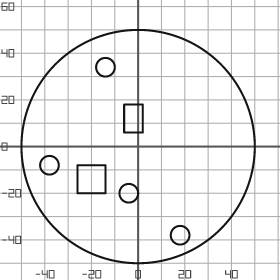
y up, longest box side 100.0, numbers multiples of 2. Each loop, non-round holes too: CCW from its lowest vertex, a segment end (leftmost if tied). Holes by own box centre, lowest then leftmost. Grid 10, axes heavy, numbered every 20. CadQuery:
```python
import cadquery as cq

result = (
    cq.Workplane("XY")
    .moveTo(0.0, 0.0)
    .circle(50.0)
    .moveTo(18.0, -38.0)
    .circle(4.0)
    .moveTo(-4.0, -20.0)
    .circle(4.0)
    .moveTo(-26.0, -20.0)
    .lineTo(-14.0, -20.0)
    .lineTo(-14.0, -8.0)
    .lineTo(-26.0, -8.0)
    .close()
    .moveTo(-38.0, -8.0)
    .circle(4.0)
    .moveTo(-6.0, 6.0)
    .lineTo(2.0, 6.0)
    .lineTo(2.0, 18.0)
    .lineTo(-6.0, 18.0)
    .close()
    .moveTo(-14.0, 34.0)
    .circle(4.0)
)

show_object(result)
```